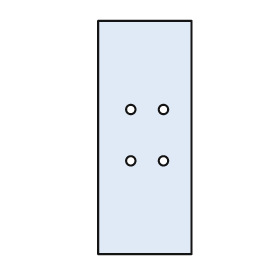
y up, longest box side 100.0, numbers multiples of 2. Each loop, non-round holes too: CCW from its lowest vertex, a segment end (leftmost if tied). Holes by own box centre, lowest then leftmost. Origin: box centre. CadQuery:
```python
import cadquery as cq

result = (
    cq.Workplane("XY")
    .moveTo(-20.0, -50.0)
    .lineTo(20.0, -50.0)
    .lineTo(20.0, 50.0)
    .lineTo(-20.0, 50.0)
    .close()
    .moveTo(-6.0, -10.0)
    .circle(2.0)
    .moveTo(8.0, -10.0)
    .circle(2.0)
    .moveTo(-6.0, 12.0)
    .circle(2.0)
    .moveTo(8.0, 12.0)
    .circle(2.0)
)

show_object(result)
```